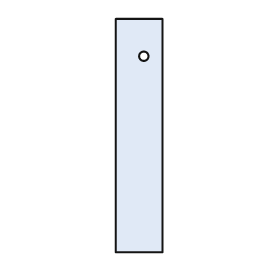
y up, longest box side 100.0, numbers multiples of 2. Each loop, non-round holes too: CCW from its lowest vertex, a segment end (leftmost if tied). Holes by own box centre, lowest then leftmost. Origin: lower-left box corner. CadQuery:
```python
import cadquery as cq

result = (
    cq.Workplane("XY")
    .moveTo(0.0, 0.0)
    .lineTo(20.0, 0.0)
    .lineTo(20.0, 100.0)
    .lineTo(0.0, 100.0)
    .close()
    .moveTo(12.0, 84.0)
    .circle(2.0)
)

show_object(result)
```